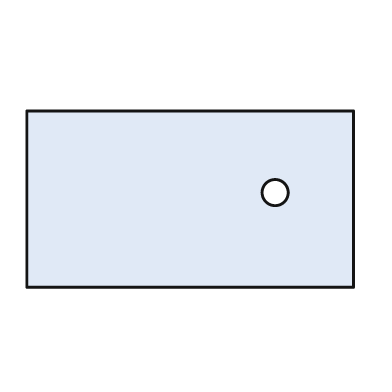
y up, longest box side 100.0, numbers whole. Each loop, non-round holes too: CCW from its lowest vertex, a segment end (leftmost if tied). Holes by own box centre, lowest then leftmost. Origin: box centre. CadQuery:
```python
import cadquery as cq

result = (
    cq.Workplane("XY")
    .moveTo(-50.0, -27.0)
    .lineTo(50.0, -27.0)
    .lineTo(50.0, 27.0)
    .lineTo(-50.0, 27.0)
    .close()
    .moveTo(26.0, 2.0)
    .circle(4.0)
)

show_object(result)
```